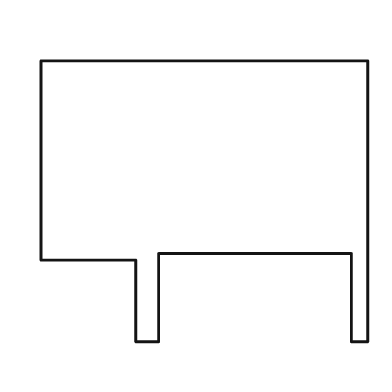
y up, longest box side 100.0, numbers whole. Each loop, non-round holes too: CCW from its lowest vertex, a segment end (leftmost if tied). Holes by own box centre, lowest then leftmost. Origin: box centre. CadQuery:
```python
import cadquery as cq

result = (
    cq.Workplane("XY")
    .moveTo(-21.0, -43.0)
    .lineTo(-14.0, -43.0)
    .lineTo(-14.0, -16.0)
    .lineTo(45.0, -16.0)
    .lineTo(45.0, -43.0)
    .lineTo(50.0, -43.0)
    .lineTo(50.0, 43.0)
    .lineTo(-50.0, 43.0)
    .lineTo(-50.0, -18.0)
    .lineTo(-21.0, -18.0)
    .close()
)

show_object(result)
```